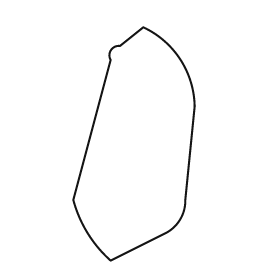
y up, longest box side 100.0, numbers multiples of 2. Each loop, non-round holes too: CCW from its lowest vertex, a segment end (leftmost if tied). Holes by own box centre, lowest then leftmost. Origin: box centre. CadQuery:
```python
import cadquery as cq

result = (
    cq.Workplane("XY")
    .moveTo(-10.0, -50.0)
    .lineTo(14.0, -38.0)
    .threePointArc((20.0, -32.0), (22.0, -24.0))
    .lineTo(26.0, 16.0)
    .threePointArc((20.0, 36.0), (4.0, 50.0))
    .lineTo(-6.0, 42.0)
    .threePointArc((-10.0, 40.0), (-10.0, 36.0))
    .lineTo(-26.0, -24.0)
    .threePointArc((-20.0, -38.0), (-10.0, -50.0))
    .close()
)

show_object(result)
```